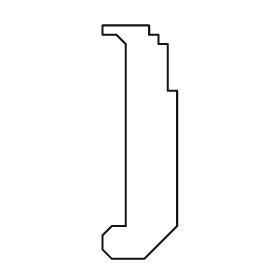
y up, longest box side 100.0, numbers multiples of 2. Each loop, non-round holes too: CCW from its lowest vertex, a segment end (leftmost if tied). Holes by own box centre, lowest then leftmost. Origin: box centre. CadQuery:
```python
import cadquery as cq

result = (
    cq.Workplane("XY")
    .moveTo(-12.0, -50.0)
    .lineTo(2.0, -50.0)
    .lineTo(16.0, -36.0)
    .lineTo(16.0, 22.0)
    .lineTo(12.0, 22.0)
    .lineTo(12.0, 42.0)
    .lineTo(8.0, 42.0)
    .lineTo(8.0, 46.0)
    .lineTo(4.0, 46.0)
    .lineTo(4.0, 50.0)
    .lineTo(-16.0, 50.0)
    .lineTo(-16.0, 46.0)
    .lineTo(-10.0, 46.0)
    .lineTo(-6.0, 42.0)
    .lineTo(-6.0, -36.0)
    .lineTo(-12.0, -36.0)
    .lineTo(-16.0, -40.0)
    .lineTo(-16.0, -46.0)
    .close()
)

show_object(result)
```